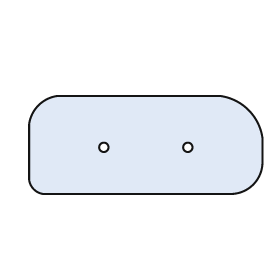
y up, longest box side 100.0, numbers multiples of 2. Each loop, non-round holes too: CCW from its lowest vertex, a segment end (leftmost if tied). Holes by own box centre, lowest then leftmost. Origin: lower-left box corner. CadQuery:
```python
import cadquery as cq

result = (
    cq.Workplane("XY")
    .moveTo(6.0, 0.0)
    .lineTo(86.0, 0.0)
    .threePointArc((96.0, 4.0), (100.0, 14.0))
    .lineTo(100.0, 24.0)
    .threePointArc((94.0, 36.0), (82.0, 42.0))
    .lineTo(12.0, 42.0)
    .threePointArc((4.0, 38.0), (0.0, 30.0))
    .lineTo(0.0, 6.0)
    .threePointArc((2.0, 2.0), (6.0, 0.0))
    .close()
    .moveTo(32.0, 20.0)
    .circle(2.0)
    .moveTo(68.0, 20.0)
    .circle(2.0)
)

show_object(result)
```